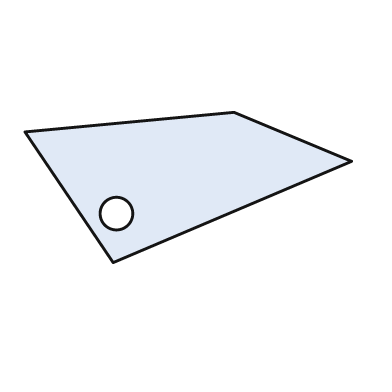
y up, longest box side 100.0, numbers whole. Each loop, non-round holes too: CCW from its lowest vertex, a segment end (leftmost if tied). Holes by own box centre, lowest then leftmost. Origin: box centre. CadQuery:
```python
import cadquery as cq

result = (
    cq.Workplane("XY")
    .moveTo(-23.0, -23.0)
    .lineTo(50.0, 8.0)
    .lineTo(14.0, 23.0)
    .lineTo(-50.0, 17.0)
    .close()
    .moveTo(-22.0, -8.0)
    .circle(5.0)
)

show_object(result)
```